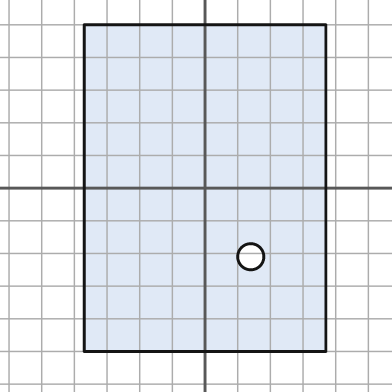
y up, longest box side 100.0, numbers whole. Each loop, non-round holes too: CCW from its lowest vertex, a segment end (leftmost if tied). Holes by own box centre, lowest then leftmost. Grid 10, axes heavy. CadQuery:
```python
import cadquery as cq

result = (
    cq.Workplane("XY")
    .moveTo(-37.0, -50.0)
    .lineTo(37.0, -50.0)
    .lineTo(37.0, 50.0)
    .lineTo(-37.0, 50.0)
    .close()
    .moveTo(14.0, -21.0)
    .circle(4.0)
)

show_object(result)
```